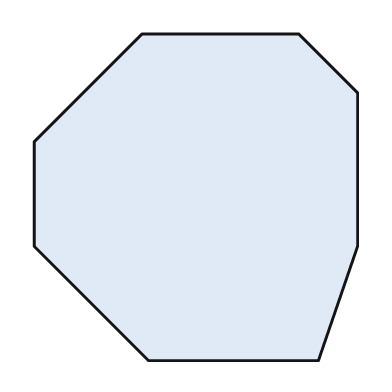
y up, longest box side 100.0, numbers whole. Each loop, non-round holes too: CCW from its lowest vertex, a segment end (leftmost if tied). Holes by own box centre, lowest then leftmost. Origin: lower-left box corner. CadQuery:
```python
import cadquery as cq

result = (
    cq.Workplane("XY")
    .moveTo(35.0, 0.0)
    .lineTo(87.0, 0.0)
    .lineTo(99.0, 35.0)
    .lineTo(99.0, 82.0)
    .lineTo(81.0, 100.0)
    .lineTo(33.0, 100.0)
    .lineTo(0.0, 67.0)
    .lineTo(0.0, 35.0)
    .close()
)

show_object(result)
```